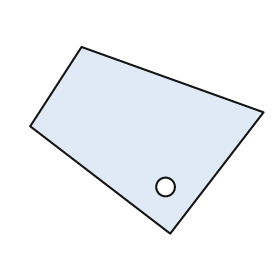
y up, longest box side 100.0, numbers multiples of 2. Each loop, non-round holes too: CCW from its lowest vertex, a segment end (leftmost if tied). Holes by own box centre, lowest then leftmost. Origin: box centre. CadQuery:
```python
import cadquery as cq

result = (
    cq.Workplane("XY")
    .moveTo(10.0, -40.0)
    .lineTo(50.0, 12.0)
    .lineTo(-28.0, 40.0)
    .lineTo(-50.0, 6.0)
    .close()
    .moveTo(8.0, -20.0)
    .circle(4.0)
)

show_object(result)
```